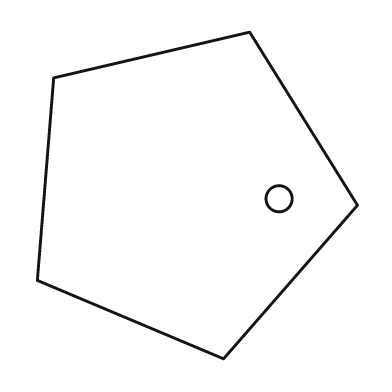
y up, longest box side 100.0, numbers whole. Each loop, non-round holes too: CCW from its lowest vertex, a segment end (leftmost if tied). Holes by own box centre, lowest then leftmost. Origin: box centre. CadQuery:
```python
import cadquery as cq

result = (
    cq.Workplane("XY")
    .moveTo(8.0, -50.0)
    .lineTo(49.0, -3.0)
    .lineTo(16.0, 50.0)
    .lineTo(-44.0, 36.0)
    .lineTo(-49.0, -26.0)
    .close()
    .moveTo(25.0, -1.0)
    .circle(4.0)
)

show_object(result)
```